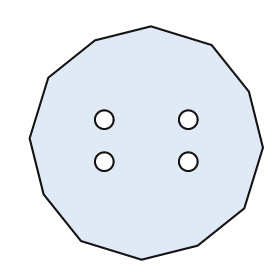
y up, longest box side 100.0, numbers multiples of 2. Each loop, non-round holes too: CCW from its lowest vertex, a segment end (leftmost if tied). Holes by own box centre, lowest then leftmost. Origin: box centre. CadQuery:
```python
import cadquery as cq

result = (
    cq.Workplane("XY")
    .moveTo(-2.0, -50.0)
    .lineTo(22.0, -44.0)
    .lineTo(42.0, -28.0)
    .lineTo(50.0, -2.0)
    .lineTo(44.0, 22.0)
    .lineTo(28.0, 42.0)
    .lineTo(2.0, 50.0)
    .lineTo(-22.0, 44.0)
    .lineTo(-42.0, 28.0)
    .lineTo(-50.0, 2.0)
    .lineTo(-44.0, -22.0)
    .lineTo(-28.0, -42.0)
    .close()
    .moveTo(-18.0, -8.0)
    .circle(4.0)
    .moveTo(18.0, -8.0)
    .circle(4.0)
    .moveTo(-18.0, 10.0)
    .circle(4.0)
    .moveTo(18.0, 10.0)
    .circle(4.0)
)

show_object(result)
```